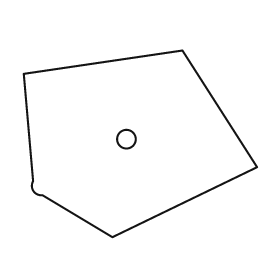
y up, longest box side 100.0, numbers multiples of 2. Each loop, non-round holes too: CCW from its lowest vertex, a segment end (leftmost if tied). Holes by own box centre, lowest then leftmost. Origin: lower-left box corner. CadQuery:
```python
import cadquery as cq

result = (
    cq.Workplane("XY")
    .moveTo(38.0, 0.0)
    .lineTo(100.0, 30.0)
    .lineTo(68.0, 80.0)
    .lineTo(0.0, 70.0)
    .lineTo(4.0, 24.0)
    .threePointArc((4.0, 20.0), (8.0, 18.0))
    .close()
    .moveTo(44.0, 42.0)
    .circle(4.0)
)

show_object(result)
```